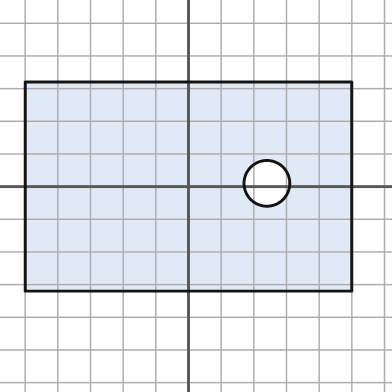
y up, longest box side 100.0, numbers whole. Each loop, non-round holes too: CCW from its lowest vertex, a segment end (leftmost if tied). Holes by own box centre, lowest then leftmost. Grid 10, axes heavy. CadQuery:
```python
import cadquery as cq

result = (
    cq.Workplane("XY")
    .moveTo(-50.0, -32.0)
    .lineTo(50.0, -32.0)
    .lineTo(50.0, 32.0)
    .lineTo(-50.0, 32.0)
    .close()
    .moveTo(24.0, 1.0)
    .circle(7.0)
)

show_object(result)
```